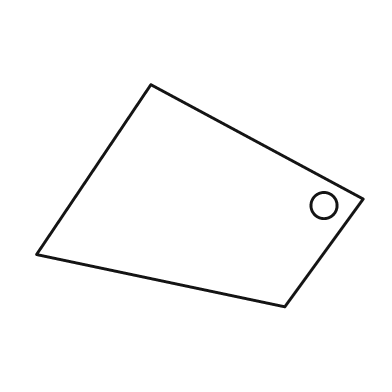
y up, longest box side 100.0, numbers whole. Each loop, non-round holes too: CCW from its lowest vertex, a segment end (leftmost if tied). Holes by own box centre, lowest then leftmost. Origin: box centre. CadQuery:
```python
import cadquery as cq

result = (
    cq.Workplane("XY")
    .moveTo(26.0, -34.0)
    .lineTo(50.0, -1.0)
    .lineTo(-15.0, 34.0)
    .lineTo(-50.0, -18.0)
    .close()
    .moveTo(38.0, -3.0)
    .circle(4.0)
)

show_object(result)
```